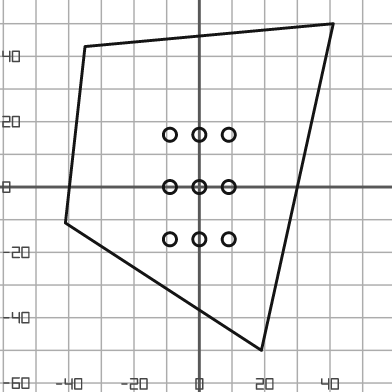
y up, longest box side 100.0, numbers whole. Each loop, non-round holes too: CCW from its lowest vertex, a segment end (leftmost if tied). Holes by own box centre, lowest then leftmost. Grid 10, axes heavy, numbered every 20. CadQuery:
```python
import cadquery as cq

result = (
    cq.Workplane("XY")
    .moveTo(19.0, -50.0)
    .lineTo(41.0, 50.0)
    .lineTo(-35.0, 43.0)
    .lineTo(-41.0, -11.0)
    .close()
    .moveTo(-9.0, -16.0)
    .circle(2.0)
    .moveTo(0.0, -16.0)
    .circle(2.0)
    .moveTo(9.0, -16.0)
    .circle(2.0)
    .moveTo(-9.0, 0.0)
    .circle(2.0)
    .moveTo(0.0, 0.0)
    .circle(2.0)
    .moveTo(9.0, 0.0)
    .circle(2.0)
    .moveTo(-9.0, 16.0)
    .circle(2.0)
    .moveTo(0.0, 16.0)
    .circle(2.0)
    .moveTo(9.0, 16.0)
    .circle(2.0)
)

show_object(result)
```